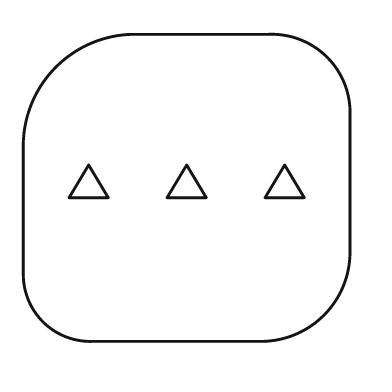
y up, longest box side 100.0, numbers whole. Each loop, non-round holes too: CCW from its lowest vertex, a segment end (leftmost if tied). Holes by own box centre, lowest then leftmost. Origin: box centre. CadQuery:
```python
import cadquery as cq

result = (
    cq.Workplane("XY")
    .moveTo(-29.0, -47.0)
    .lineTo(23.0, -47.0)
    .threePointArc((42.0, -39.0), (50.0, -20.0))
    .lineTo(50.0, 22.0)
    .threePointArc((43.0, 40.0), (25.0, 47.0))
    .lineTo(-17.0, 47.0)
    .threePointArc((-40.0, 37.0), (-50.0, 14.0))
    .lineTo(-50.0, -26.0)
    .threePointArc((-44.0, -41.0), (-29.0, -47.0))
    .close()
    .moveTo(-36.0, -3.0)
    .lineTo(-24.0, -3.0)
    .lineTo(-30.0, 7.0)
    .close()
    .moveTo(-6.0, -3.0)
    .lineTo(6.0, -3.0)
    .lineTo(0.0, 7.0)
    .close()
    .moveTo(24.0, -3.0)
    .lineTo(36.0, -3.0)
    .lineTo(30.0, 7.0)
    .close()
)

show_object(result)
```